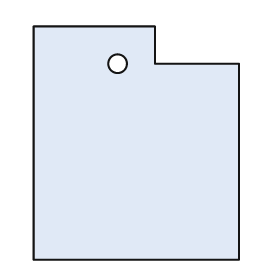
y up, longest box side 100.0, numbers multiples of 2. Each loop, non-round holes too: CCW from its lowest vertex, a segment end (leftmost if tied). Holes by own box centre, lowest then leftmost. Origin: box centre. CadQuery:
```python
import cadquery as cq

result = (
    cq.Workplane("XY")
    .moveTo(-44.0, -50.0)
    .lineTo(44.0, -50.0)
    .lineTo(44.0, 34.0)
    .lineTo(8.0, 34.0)
    .lineTo(8.0, 50.0)
    .lineTo(-44.0, 50.0)
    .close()
    .moveTo(-8.0, 34.0)
    .circle(4.0)
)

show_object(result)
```